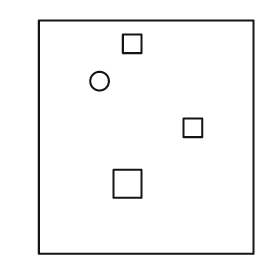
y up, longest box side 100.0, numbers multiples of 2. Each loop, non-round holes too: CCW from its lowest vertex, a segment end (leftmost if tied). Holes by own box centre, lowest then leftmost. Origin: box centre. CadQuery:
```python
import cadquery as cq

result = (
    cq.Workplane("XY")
    .moveTo(-46.0, -50.0)
    .lineTo(46.0, -50.0)
    .lineTo(46.0, 50.0)
    .lineTo(-46.0, 50.0)
    .close()
    .moveTo(-14.0, -26.0)
    .lineTo(-2.0, -26.0)
    .lineTo(-2.0, -14.0)
    .lineTo(-14.0, -14.0)
    .close()
    .moveTo(16.0, 0.0)
    .lineTo(24.0, 0.0)
    .lineTo(24.0, 8.0)
    .lineTo(16.0, 8.0)
    .close()
    .moveTo(-20.0, 24.0)
    .circle(4.0)
    .moveTo(-10.0, 36.0)
    .lineTo(-2.0, 36.0)
    .lineTo(-2.0, 44.0)
    .lineTo(-10.0, 44.0)
    .close()
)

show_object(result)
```